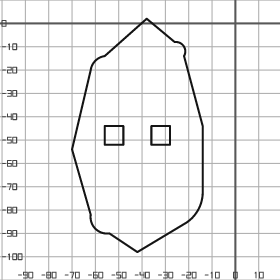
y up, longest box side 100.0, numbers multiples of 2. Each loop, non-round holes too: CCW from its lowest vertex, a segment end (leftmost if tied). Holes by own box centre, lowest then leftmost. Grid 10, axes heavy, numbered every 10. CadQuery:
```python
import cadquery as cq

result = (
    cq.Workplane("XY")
    .moveTo(-42.0, -98.0)
    .lineTo(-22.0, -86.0)
    .threePointArc((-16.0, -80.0), (-14.0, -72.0))
    .lineTo(-14.0, -44.0)
    .lineTo(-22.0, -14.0)
    .threePointArc((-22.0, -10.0), (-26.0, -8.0))
    .lineTo(-38.0, 2.0)
    .lineTo(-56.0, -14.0)
    .threePointArc((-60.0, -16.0), (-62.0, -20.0))
    .lineTo(-70.0, -54.0)
    .lineTo(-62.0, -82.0)
    .threePointArc((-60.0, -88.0), (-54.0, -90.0))
    .close()
    .moveTo(-56.0, -52.0)
    .lineTo(-48.0, -52.0)
    .lineTo(-48.0, -44.0)
    .lineTo(-56.0, -44.0)
    .close()
    .moveTo(-36.0, -52.0)
    .lineTo(-28.0, -52.0)
    .lineTo(-28.0, -44.0)
    .lineTo(-36.0, -44.0)
    .close()
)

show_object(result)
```